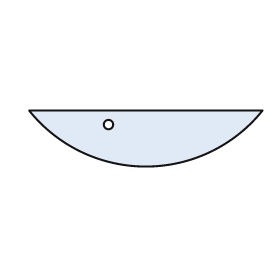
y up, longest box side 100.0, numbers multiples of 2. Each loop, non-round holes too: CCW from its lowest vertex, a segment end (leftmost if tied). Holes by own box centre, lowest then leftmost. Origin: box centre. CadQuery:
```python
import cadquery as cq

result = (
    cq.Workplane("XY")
    .moveTo(-50.0, 12.0)
    .threePointArc((0.0, -12.0), (50.0, 12.0))
    .close()
    .moveTo(-16.0, 6.0)
    .circle(2.0)
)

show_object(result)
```